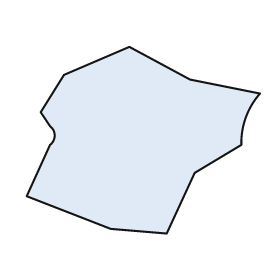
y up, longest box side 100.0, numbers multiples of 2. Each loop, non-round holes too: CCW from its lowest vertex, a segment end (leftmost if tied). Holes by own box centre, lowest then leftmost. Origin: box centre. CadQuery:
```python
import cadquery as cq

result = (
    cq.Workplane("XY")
    .moveTo(10.0, -40.0)
    .lineTo(22.0, -14.0)
    .lineTo(42.0, -2.0)
    .threePointArc((44.0, 10.0), (50.0, 20.0))
    .lineTo(20.0, 26.0)
    .lineTo(-6.0, 40.0)
    .lineTo(-34.0, 28.0)
    .lineTo(-44.0, 12.0)
    .lineTo(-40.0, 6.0)
    .threePointArc((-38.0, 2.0), (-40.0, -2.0))
    .lineTo(-50.0, -24.0)
    .lineTo(-14.0, -38.0)
    .close()
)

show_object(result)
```